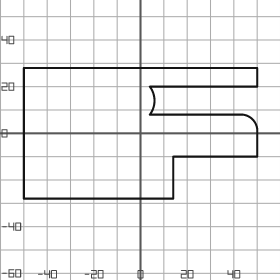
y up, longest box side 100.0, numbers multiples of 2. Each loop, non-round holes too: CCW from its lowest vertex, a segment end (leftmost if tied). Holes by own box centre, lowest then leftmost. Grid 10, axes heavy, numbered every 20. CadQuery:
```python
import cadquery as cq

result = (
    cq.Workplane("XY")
    .moveTo(-50.0, -28.0)
    .lineTo(14.0, -28.0)
    .lineTo(14.0, -10.0)
    .lineTo(50.0, -10.0)
    .lineTo(50.0, 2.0)
    .threePointArc((48.0, 6.0), (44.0, 8.0))
    .lineTo(4.0, 8.0)
    .threePointArc((6.0, 14.0), (4.0, 20.0))
    .lineTo(50.0, 20.0)
    .lineTo(50.0, 28.0)
    .lineTo(-50.0, 28.0)
    .close()
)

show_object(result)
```